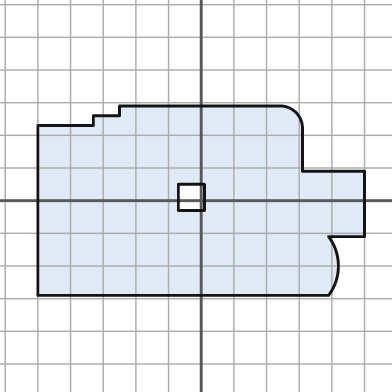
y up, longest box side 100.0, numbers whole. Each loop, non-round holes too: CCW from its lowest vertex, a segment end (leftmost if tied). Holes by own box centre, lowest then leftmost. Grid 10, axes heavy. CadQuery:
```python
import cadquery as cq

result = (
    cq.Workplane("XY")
    .moveTo(-50.0, -29.0)
    .lineTo(39.0, -29.0)
    .threePointArc((42.0, -20.0), (39.0, -11.0))
    .lineTo(50.0, -11.0)
    .lineTo(50.0, 9.0)
    .lineTo(31.0, 9.0)
    .lineTo(31.0, 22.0)
    .threePointArc((29.0, 27.0), (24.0, 29.0))
    .lineTo(-25.0, 29.0)
    .lineTo(-25.0, 26.0)
    .lineTo(-33.0, 26.0)
    .lineTo(-33.0, 23.0)
    .lineTo(-50.0, 23.0)
    .close()
    .moveTo(-7.0, -3.0)
    .lineTo(1.0, -3.0)
    .lineTo(1.0, 5.0)
    .lineTo(-7.0, 5.0)
    .close()
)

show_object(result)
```